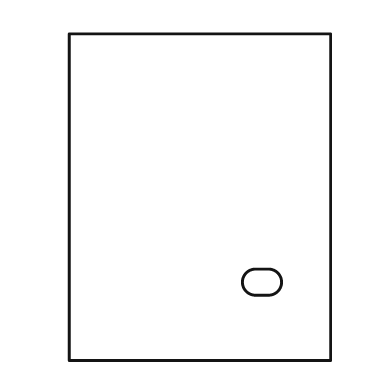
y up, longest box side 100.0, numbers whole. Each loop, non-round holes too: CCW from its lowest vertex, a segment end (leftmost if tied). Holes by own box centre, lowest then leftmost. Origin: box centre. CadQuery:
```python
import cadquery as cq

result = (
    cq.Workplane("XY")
    .moveTo(-40.0, -50.0)
    .lineTo(40.0, -50.0)
    .lineTo(40.0, 50.0)
    .lineTo(-40.0, 50.0)
    .close()
    .moveTo(17.0, -30.0)
    .lineTo(21.0, -30.0)
    .threePointArc((25.0, -26.0), (21.0, -22.0))
    .lineTo(17.0, -22.0)
    .threePointArc((13.0, -26.0), (17.0, -30.0))
    .close()
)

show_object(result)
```